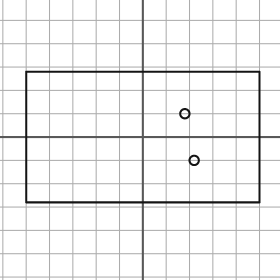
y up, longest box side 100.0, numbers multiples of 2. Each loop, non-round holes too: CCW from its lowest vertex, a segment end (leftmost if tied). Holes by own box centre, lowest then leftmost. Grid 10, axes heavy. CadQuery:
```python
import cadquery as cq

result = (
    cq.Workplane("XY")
    .moveTo(-50.0, -28.0)
    .lineTo(50.0, -28.0)
    .lineTo(50.0, 28.0)
    .lineTo(-50.0, 28.0)
    .close()
    .moveTo(22.0, -10.0)
    .circle(2.0)
    .moveTo(18.0, 10.0)
    .circle(2.0)
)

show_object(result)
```